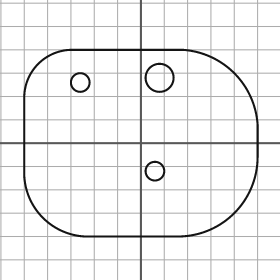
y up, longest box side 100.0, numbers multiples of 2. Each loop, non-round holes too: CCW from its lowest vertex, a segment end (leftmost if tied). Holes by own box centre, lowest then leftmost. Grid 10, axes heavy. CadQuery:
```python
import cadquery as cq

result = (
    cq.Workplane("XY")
    .moveTo(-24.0, -40.0)
    .lineTo(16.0, -40.0)
    .threePointArc((40.0, -30.0), (50.0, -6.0))
    .lineTo(50.0, 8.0)
    .threePointArc((40.0, 30.0), (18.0, 40.0))
    .lineTo(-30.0, 40.0)
    .threePointArc((-44.0, 34.0), (-50.0, 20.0))
    .lineTo(-50.0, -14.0)
    .threePointArc((-42.0, -32.0), (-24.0, -40.0))
    .close()
    .moveTo(6.0, -12.0)
    .circle(4.0)
    .moveTo(-26.0, 26.0)
    .circle(4.0)
    .moveTo(8.0, 28.0)
    .circle(6.0)
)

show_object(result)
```